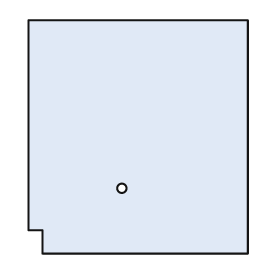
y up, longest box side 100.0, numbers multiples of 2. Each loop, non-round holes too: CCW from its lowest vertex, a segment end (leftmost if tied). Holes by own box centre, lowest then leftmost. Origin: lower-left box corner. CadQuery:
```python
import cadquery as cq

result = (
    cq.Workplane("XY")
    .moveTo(6.0, 0.0)
    .lineTo(94.0, 0.0)
    .lineTo(94.0, 100.0)
    .lineTo(0.0, 100.0)
    .lineTo(0.0, 10.0)
    .lineTo(6.0, 10.0)
    .close()
    .moveTo(40.0, 28.0)
    .circle(2.0)
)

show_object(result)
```